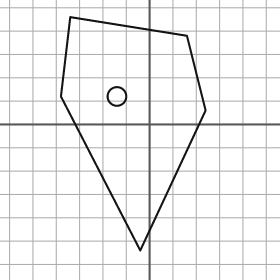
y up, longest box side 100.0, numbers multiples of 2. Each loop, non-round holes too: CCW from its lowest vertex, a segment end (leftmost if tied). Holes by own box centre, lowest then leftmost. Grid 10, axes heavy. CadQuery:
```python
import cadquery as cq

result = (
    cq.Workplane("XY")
    .moveTo(-4.0, -54.0)
    .lineTo(24.0, 6.0)
    .lineTo(16.0, 38.0)
    .lineTo(-34.0, 46.0)
    .lineTo(-38.0, 12.0)
    .close()
    .moveTo(-14.0, 12.0)
    .circle(4.0)
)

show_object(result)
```